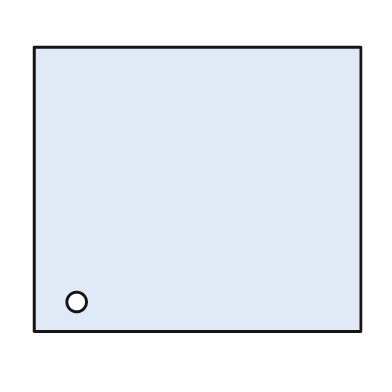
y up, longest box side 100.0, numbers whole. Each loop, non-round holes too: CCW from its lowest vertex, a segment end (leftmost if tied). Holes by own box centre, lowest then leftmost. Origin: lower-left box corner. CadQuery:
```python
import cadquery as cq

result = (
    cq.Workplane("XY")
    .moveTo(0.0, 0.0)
    .lineTo(100.0, 0.0)
    .lineTo(100.0, 87.0)
    .lineTo(0.0, 87.0)
    .close()
    .moveTo(13.0, 9.0)
    .circle(3.0)
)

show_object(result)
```